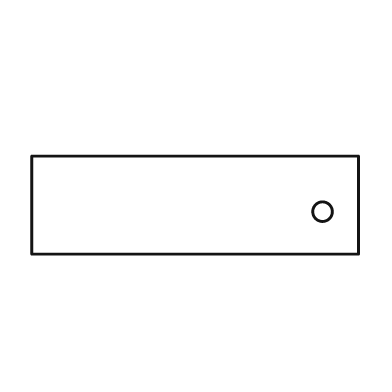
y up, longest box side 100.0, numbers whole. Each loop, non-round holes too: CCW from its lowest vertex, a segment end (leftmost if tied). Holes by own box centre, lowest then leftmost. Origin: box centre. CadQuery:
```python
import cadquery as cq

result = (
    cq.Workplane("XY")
    .moveTo(-50.0, -15.0)
    .lineTo(50.0, -15.0)
    .lineTo(50.0, 15.0)
    .lineTo(-50.0, 15.0)
    .close()
    .moveTo(39.0, -2.0)
    .circle(3.0)
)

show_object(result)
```